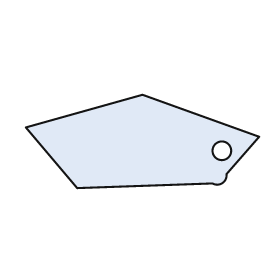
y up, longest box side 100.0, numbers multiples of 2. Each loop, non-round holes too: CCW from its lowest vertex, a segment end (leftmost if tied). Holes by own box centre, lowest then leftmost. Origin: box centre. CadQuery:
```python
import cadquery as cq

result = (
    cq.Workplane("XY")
    .moveTo(-28.0, -20.0)
    .lineTo(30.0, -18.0)
    .threePointArc((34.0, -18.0), (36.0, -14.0))
    .lineTo(50.0, 2.0)
    .lineTo(0.0, 20.0)
    .lineTo(-50.0, 6.0)
    .close()
    .moveTo(34.0, -4.0)
    .circle(4.0)
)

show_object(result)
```